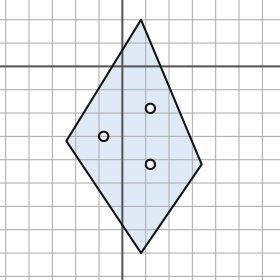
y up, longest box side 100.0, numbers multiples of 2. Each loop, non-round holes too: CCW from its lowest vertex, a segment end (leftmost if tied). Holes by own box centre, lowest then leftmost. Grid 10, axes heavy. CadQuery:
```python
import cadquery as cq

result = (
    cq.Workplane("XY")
    .moveTo(8.0, -80.0)
    .lineTo(34.0, -42.0)
    .lineTo(8.0, 20.0)
    .lineTo(-24.0, -32.0)
    .close()
    .moveTo(12.0, -42.0)
    .circle(2.0)
    .moveTo(-8.0, -30.0)
    .circle(2.0)
    .moveTo(12.0, -18.0)
    .circle(2.0)
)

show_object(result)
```